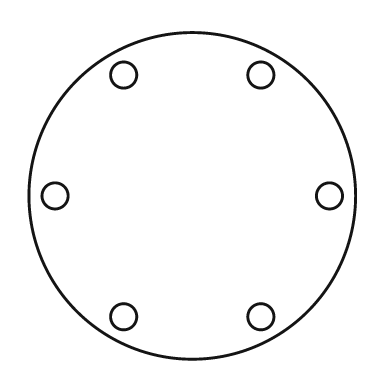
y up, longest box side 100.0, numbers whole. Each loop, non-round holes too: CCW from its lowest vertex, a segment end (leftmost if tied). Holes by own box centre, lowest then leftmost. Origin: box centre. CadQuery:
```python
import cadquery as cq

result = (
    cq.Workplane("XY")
    .moveTo(0.0, 0.0)
    .circle(50.0)
    .moveTo(-21.0, -37.0)
    .circle(4.0)
    .moveTo(21.0, -37.0)
    .circle(4.0)
    .moveTo(-42.0, 0.0)
    .circle(4.0)
    .moveTo(42.0, 0.0)
    .circle(4.0)
    .moveTo(-21.0, 37.0)
    .circle(4.0)
    .moveTo(21.0, 37.0)
    .circle(4.0)
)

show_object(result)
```